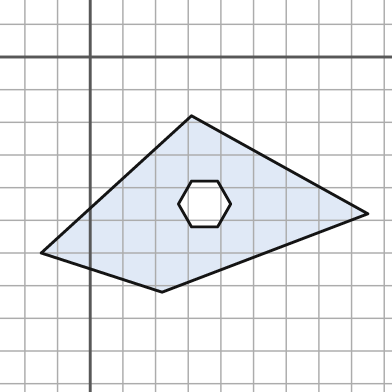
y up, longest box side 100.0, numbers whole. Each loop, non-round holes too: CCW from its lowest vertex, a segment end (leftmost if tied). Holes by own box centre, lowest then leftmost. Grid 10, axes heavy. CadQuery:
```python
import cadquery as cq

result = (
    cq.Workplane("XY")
    .moveTo(22.0, -72.0)
    .lineTo(85.0, -48.0)
    .lineTo(31.0, -18.0)
    .lineTo(-15.0, -60.0)
    .close()
    .moveTo(31.0, -52.0)
    .lineTo(39.0, -52.0)
    .lineTo(43.0, -45.0)
    .lineTo(39.0, -38.0)
    .lineTo(31.0, -38.0)
    .lineTo(27.0, -45.0)
    .close()
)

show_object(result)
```